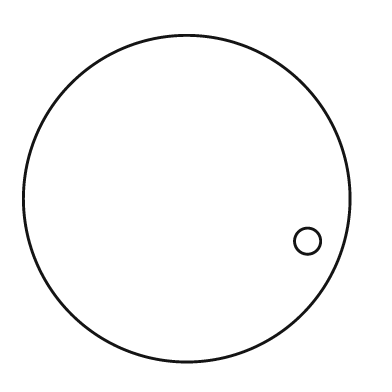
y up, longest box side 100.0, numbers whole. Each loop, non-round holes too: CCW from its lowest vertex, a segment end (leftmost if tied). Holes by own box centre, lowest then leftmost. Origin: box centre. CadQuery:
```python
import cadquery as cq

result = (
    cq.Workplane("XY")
    .moveTo(0.0, 0.0)
    .circle(50.0)
    .moveTo(37.0, -13.0)
    .circle(4.0)
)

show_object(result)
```